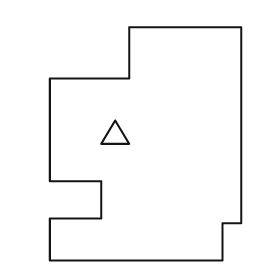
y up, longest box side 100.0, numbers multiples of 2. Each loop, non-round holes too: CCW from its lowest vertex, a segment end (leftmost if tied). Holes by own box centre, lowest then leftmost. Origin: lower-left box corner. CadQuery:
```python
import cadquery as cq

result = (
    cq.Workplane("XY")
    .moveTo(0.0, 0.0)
    .lineTo(74.0, 0.0)
    .lineTo(74.0, 16.0)
    .lineTo(82.0, 16.0)
    .lineTo(82.0, 100.0)
    .lineTo(34.0, 100.0)
    .lineTo(34.0, 78.0)
    .lineTo(0.0, 78.0)
    .lineTo(0.0, 34.0)
    .lineTo(22.0, 34.0)
    .lineTo(22.0, 18.0)
    .lineTo(0.0, 18.0)
    .close()
    .moveTo(22.0, 50.0)
    .lineTo(34.0, 50.0)
    .lineTo(28.0, 60.0)
    .close()
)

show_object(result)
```